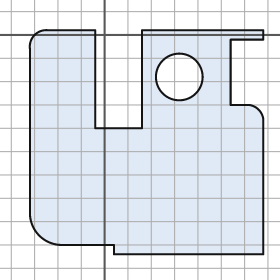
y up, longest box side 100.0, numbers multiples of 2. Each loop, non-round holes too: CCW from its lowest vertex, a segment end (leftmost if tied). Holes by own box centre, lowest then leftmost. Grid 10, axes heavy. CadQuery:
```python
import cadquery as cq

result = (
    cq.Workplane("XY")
    .moveTo(4.0, -94.0)
    .lineTo(68.0, -94.0)
    .lineTo(68.0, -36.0)
    .threePointArc((66.0, -32.0), (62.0, -30.0))
    .lineTo(54.0, -30.0)
    .lineTo(54.0, -2.0)
    .lineTo(68.0, -2.0)
    .lineTo(68.0, 2.0)
    .lineTo(16.0, 2.0)
    .lineTo(16.0, -40.0)
    .lineTo(-4.0, -40.0)
    .lineTo(-4.0, 2.0)
    .lineTo(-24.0, 2.0)
    .threePointArc((-30.0, 0.0), (-32.0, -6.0))
    .lineTo(-32.0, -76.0)
    .threePointArc((-28.0, -86.0), (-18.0, -90.0))
    .lineTo(4.0, -90.0)
    .close()
    .moveTo(32.0, -18.0)
    .circle(10.0)
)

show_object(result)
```